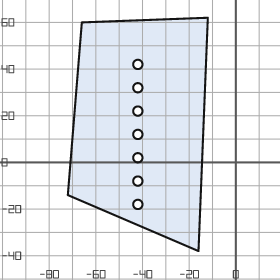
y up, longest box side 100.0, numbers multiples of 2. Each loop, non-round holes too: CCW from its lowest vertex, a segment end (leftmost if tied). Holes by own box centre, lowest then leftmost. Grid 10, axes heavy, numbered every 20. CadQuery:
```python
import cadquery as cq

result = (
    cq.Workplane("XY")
    .moveTo(-16.0, -38.0)
    .lineTo(-12.0, 62.0)
    .lineTo(-66.0, 60.0)
    .lineTo(-72.0, -14.0)
    .close()
    .moveTo(-42.0, -18.0)
    .circle(2.0)
    .moveTo(-42.0, -8.0)
    .circle(2.0)
    .moveTo(-42.0, 2.0)
    .circle(2.0)
    .moveTo(-42.0, 12.0)
    .circle(2.0)
    .moveTo(-42.0, 22.0)
    .circle(2.0)
    .moveTo(-42.0, 32.0)
    .circle(2.0)
    .moveTo(-42.0, 42.0)
    .circle(2.0)
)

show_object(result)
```